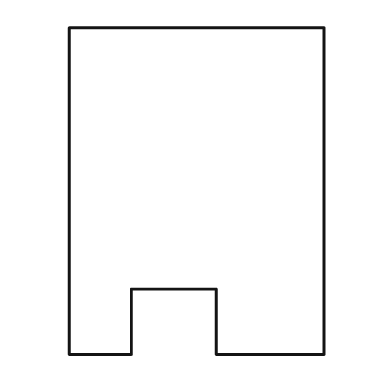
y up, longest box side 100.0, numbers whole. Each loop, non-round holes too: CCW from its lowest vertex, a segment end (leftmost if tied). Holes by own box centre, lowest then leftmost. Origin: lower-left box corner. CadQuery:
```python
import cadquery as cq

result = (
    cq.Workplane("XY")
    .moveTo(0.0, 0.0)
    .lineTo(19.0, 0.0)
    .lineTo(19.0, 20.0)
    .lineTo(45.0, 20.0)
    .lineTo(45.0, 0.0)
    .lineTo(78.0, 0.0)
    .lineTo(78.0, 100.0)
    .lineTo(0.0, 100.0)
    .close()
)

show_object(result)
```